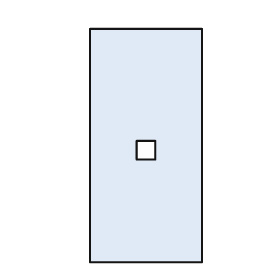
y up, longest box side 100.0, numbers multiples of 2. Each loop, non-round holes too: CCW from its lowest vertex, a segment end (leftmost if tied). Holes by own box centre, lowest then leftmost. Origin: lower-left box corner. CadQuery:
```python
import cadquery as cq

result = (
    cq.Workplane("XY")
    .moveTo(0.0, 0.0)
    .lineTo(48.0, 0.0)
    .lineTo(48.0, 100.0)
    .lineTo(0.0, 100.0)
    .close()
    .moveTo(20.0, 44.0)
    .lineTo(28.0, 44.0)
    .lineTo(28.0, 52.0)
    .lineTo(20.0, 52.0)
    .close()
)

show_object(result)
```